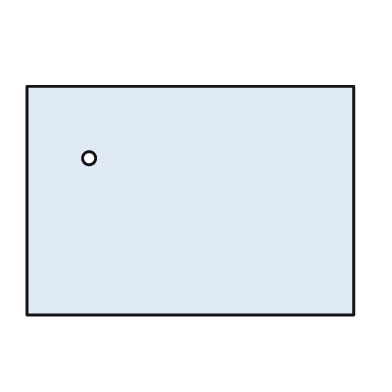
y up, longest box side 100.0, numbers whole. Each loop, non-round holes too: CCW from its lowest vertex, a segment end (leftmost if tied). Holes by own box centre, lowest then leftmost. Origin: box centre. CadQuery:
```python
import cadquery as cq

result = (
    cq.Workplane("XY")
    .moveTo(-50.0, -35.0)
    .lineTo(50.0, -35.0)
    .lineTo(50.0, 35.0)
    .lineTo(-50.0, 35.0)
    .close()
    .moveTo(-31.0, 13.0)
    .circle(2.0)
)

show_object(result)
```